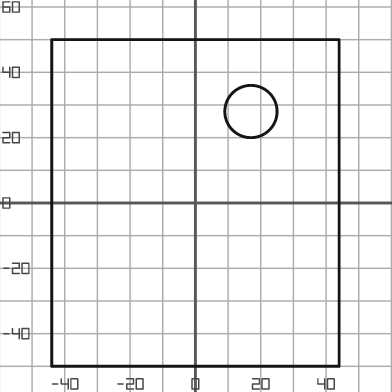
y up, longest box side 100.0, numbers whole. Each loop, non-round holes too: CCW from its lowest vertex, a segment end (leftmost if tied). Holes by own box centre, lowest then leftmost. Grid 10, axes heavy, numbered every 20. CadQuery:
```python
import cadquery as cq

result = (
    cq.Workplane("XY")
    .moveTo(-44.0, -50.0)
    .lineTo(44.0, -50.0)
    .lineTo(44.0, 50.0)
    .lineTo(-44.0, 50.0)
    .close()
    .moveTo(17.0, 28.0)
    .circle(8.0)
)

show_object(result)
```